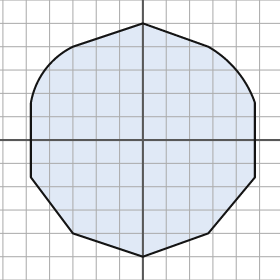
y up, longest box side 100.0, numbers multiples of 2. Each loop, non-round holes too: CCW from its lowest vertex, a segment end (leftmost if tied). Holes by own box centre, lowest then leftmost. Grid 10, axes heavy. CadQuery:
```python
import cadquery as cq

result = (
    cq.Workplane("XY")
    .moveTo(0.0, -50.0)
    .lineTo(28.0, -40.0)
    .lineTo(48.0, -16.0)
    .lineTo(48.0, 16.0)
    .threePointArc((40.0, 30.0), (28.0, 40.0))
    .lineTo(0.0, 50.0)
    .lineTo(-30.0, 40.0)
    .threePointArc((-42.0, 30.0), (-48.0, 16.0))
    .lineTo(-48.0, -16.0)
    .lineTo(-30.0, -40.0)
    .close()
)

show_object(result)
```